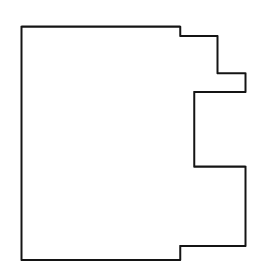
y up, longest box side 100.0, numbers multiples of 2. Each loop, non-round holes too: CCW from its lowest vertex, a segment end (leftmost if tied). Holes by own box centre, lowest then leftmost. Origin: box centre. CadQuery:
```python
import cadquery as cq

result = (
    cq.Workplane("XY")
    .moveTo(-48.0, -50.0)
    .lineTo(20.0, -50.0)
    .lineTo(20.0, -44.0)
    .lineTo(48.0, -44.0)
    .lineTo(48.0, -10.0)
    .lineTo(26.0, -10.0)
    .lineTo(26.0, 22.0)
    .lineTo(48.0, 22.0)
    .lineTo(48.0, 30.0)
    .lineTo(36.0, 30.0)
    .lineTo(36.0, 46.0)
    .lineTo(20.0, 46.0)
    .lineTo(20.0, 50.0)
    .lineTo(-48.0, 50.0)
    .close()
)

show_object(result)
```